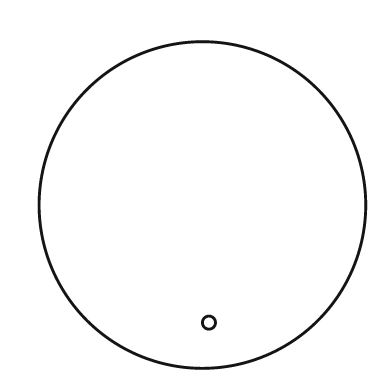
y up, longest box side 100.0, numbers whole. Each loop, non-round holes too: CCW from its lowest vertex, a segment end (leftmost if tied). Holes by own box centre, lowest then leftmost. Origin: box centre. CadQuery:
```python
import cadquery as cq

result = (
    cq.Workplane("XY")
    .moveTo(0.0, 0.0)
    .circle(50.0)
    .moveTo(2.0, -36.0)
    .circle(2.0)
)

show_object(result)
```